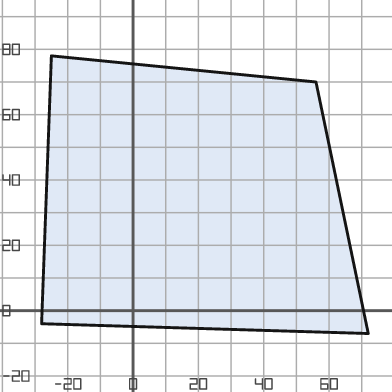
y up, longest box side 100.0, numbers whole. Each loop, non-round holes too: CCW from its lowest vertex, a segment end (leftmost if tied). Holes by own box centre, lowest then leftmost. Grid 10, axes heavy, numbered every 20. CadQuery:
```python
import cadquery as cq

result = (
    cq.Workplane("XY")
    .moveTo(72.0, -7.0)
    .lineTo(56.0, 70.0)
    .lineTo(-25.0, 78.0)
    .lineTo(-28.0, -4.0)
    .close()
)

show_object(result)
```